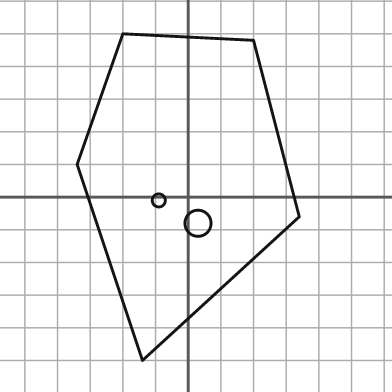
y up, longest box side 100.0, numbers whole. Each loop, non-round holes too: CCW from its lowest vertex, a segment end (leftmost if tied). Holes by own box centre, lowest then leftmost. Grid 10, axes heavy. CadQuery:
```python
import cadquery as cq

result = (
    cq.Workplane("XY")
    .moveTo(-14.0, -50.0)
    .lineTo(34.0, -6.0)
    .lineTo(20.0, 48.0)
    .lineTo(-20.0, 50.0)
    .lineTo(-34.0, 10.0)
    .close()
    .moveTo(3.0, -8.0)
    .circle(4.0)
    .moveTo(-9.0, -1.0)
    .circle(2.0)
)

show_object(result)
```